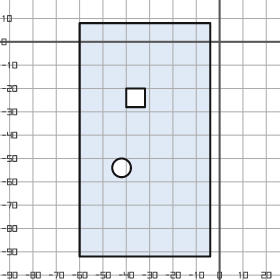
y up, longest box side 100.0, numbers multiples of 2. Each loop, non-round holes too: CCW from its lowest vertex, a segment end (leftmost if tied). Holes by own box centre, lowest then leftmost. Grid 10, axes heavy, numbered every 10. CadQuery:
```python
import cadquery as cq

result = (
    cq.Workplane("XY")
    .moveTo(-60.0, -92.0)
    .lineTo(-4.0, -92.0)
    .lineTo(-4.0, 8.0)
    .lineTo(-60.0, 8.0)
    .close()
    .moveTo(-42.0, -54.0)
    .circle(4.0)
    .moveTo(-40.0, -28.0)
    .lineTo(-32.0, -28.0)
    .lineTo(-32.0, -20.0)
    .lineTo(-40.0, -20.0)
    .close()
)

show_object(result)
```